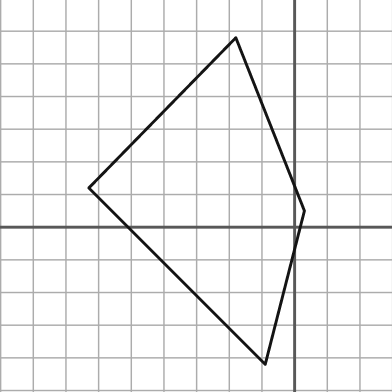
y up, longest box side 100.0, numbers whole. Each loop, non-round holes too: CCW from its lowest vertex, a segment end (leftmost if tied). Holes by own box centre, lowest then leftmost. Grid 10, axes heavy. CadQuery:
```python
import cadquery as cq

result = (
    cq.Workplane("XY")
    .moveTo(-9.0, -42.0)
    .lineTo(3.0, 5.0)
    .lineTo(-18.0, 58.0)
    .lineTo(-63.0, 12.0)
    .close()
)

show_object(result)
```